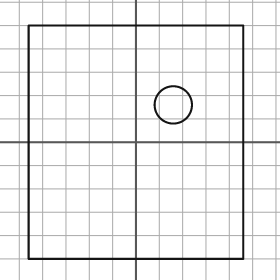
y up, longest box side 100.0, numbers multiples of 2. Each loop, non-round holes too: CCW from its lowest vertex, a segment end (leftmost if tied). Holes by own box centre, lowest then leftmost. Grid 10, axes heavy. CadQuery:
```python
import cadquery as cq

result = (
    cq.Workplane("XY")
    .moveTo(-46.0, -50.0)
    .lineTo(46.0, -50.0)
    .lineTo(46.0, 50.0)
    .lineTo(-46.0, 50.0)
    .close()
    .moveTo(16.0, 16.0)
    .circle(8.0)
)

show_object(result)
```